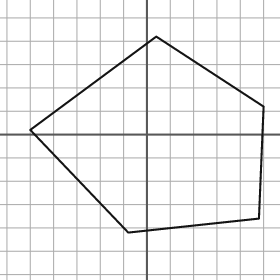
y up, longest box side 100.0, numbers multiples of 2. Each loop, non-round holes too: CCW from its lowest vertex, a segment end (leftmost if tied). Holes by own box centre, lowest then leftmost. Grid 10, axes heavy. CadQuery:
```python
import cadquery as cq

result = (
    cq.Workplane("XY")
    .moveTo(-8.0, -42.0)
    .lineTo(48.0, -36.0)
    .lineTo(50.0, 12.0)
    .lineTo(4.0, 42.0)
    .lineTo(-50.0, 2.0)
    .close()
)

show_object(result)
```